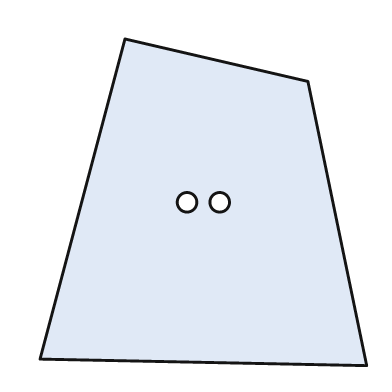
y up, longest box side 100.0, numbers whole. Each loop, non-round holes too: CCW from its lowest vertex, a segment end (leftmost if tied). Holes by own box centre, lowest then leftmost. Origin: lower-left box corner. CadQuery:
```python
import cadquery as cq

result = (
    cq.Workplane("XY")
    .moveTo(100.0, 0.0)
    .lineTo(82.0, 87.0)
    .lineTo(26.0, 100.0)
    .lineTo(0.0, 2.0)
    .close()
    .moveTo(45.0, 50.0)
    .circle(3.0)
    .moveTo(55.0, 50.0)
    .circle(3.0)
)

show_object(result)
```